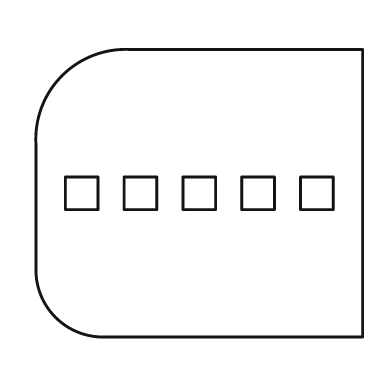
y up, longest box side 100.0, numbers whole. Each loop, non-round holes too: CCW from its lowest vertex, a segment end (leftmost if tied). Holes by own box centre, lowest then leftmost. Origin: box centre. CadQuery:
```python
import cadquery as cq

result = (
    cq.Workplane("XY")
    .moveTo(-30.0, -44.0)
    .lineTo(50.0, -44.0)
    .lineTo(50.0, 44.0)
    .lineTo(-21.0, 44.0)
    .threePointArc((-42.0, 36.0), (-50.0, 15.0))
    .lineTo(-50.0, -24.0)
    .threePointArc((-44.0, -38.0), (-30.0, -44.0))
    .close()
    .moveTo(-41.0, -5.0)
    .lineTo(-31.0, -5.0)
    .lineTo(-31.0, 5.0)
    .lineTo(-41.0, 5.0)
    .close()
    .moveTo(-23.0, -5.0)
    .lineTo(-13.0, -5.0)
    .lineTo(-13.0, 5.0)
    .lineTo(-23.0, 5.0)
    .close()
    .moveTo(-5.0, -5.0)
    .lineTo(5.0, -5.0)
    .lineTo(5.0, 5.0)
    .lineTo(-5.0, 5.0)
    .close()
    .moveTo(13.0, -5.0)
    .lineTo(23.0, -5.0)
    .lineTo(23.0, 5.0)
    .lineTo(13.0, 5.0)
    .close()
    .moveTo(31.0, -5.0)
    .lineTo(41.0, -5.0)
    .lineTo(41.0, 5.0)
    .lineTo(31.0, 5.0)
    .close()
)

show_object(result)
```